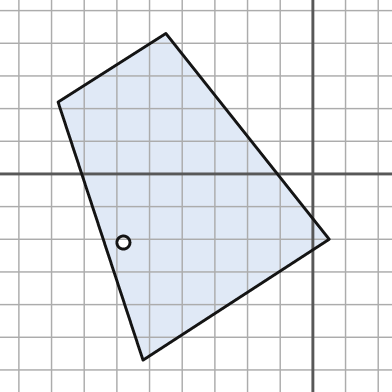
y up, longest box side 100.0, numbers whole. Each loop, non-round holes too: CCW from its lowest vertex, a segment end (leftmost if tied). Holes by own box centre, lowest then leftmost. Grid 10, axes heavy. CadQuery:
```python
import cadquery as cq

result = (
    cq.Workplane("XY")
    .moveTo(-52.0, -57.0)
    .lineTo(5.0, -20.0)
    .lineTo(-45.0, 43.0)
    .lineTo(-78.0, 22.0)
    .close()
    .moveTo(-58.0, -21.0)
    .circle(2.0)
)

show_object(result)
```